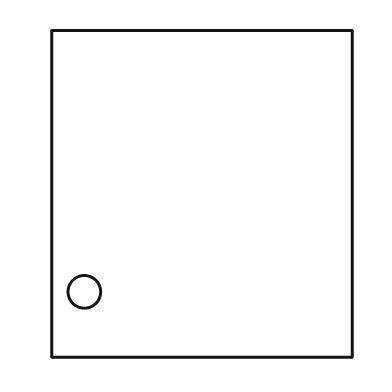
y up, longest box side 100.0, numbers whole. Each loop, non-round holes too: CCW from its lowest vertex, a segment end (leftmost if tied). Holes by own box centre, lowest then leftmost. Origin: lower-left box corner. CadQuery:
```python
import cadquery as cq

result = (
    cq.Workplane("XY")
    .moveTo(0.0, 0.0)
    .lineTo(92.0, 0.0)
    .lineTo(92.0, 100.0)
    .lineTo(0.0, 100.0)
    .close()
    .moveTo(10.0, 20.0)
    .circle(5.0)
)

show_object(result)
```